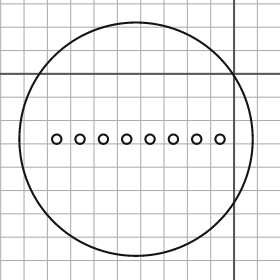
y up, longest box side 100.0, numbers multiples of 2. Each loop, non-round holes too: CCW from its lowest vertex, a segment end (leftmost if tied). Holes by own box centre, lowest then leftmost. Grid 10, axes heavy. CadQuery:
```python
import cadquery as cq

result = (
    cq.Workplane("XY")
    .moveTo(-42.0, -28.0)
    .circle(50.0)
    .moveTo(-76.0, -28.0)
    .circle(2.0)
    .moveTo(-66.0, -28.0)
    .circle(2.0)
    .moveTo(-56.0, -28.0)
    .circle(2.0)
    .moveTo(-46.0, -28.0)
    .circle(2.0)
    .moveTo(-36.0, -28.0)
    .circle(2.0)
    .moveTo(-26.0, -28.0)
    .circle(2.0)
    .moveTo(-16.0, -28.0)
    .circle(2.0)
    .moveTo(-6.0, -28.0)
    .circle(2.0)
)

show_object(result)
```